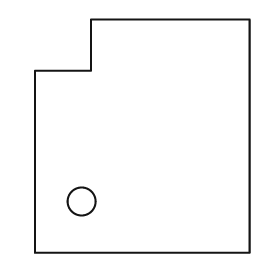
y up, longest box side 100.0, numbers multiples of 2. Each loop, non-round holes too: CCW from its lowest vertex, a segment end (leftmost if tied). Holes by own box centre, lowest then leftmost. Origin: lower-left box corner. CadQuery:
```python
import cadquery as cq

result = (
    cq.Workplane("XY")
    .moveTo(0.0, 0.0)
    .lineTo(92.0, 0.0)
    .lineTo(92.0, 100.0)
    .lineTo(24.0, 100.0)
    .lineTo(24.0, 78.0)
    .lineTo(0.0, 78.0)
    .close()
    .moveTo(20.0, 22.0)
    .circle(6.0)
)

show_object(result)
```